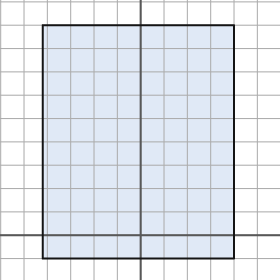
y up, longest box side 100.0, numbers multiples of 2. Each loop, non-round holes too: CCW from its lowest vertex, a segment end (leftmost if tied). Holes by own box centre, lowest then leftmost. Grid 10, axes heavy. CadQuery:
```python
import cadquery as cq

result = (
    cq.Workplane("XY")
    .moveTo(-42.0, -10.0)
    .lineTo(40.0, -10.0)
    .lineTo(40.0, 90.0)
    .lineTo(-42.0, 90.0)
    .close()
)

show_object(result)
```